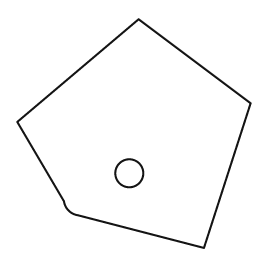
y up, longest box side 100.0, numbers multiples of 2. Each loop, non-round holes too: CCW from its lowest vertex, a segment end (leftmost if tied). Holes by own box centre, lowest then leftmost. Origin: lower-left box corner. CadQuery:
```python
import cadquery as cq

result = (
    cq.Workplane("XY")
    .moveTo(80.0, 0.0)
    .lineTo(100.0, 62.0)
    .lineTo(52.0, 98.0)
    .lineTo(0.0, 54.0)
    .lineTo(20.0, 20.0)
    .threePointArc((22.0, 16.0), (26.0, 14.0))
    .close()
    .moveTo(48.0, 32.0)
    .circle(6.0)
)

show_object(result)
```